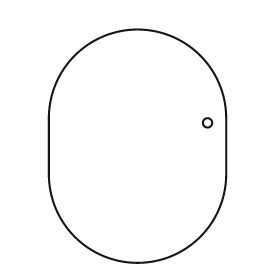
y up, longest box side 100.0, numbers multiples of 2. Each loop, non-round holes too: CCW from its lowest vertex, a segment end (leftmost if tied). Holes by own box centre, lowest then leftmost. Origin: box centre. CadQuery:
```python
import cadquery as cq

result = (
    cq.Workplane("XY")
    .moveTo(-38.0, -12.0)
    .threePointArc((0.0, -50.0), (38.0, -12.0))
    .lineTo(38.0, 12.0)
    .threePointArc((0.0, 50.0), (-38.0, 12.0))
    .close()
    .moveTo(30.0, 10.0)
    .circle(2.0)
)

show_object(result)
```